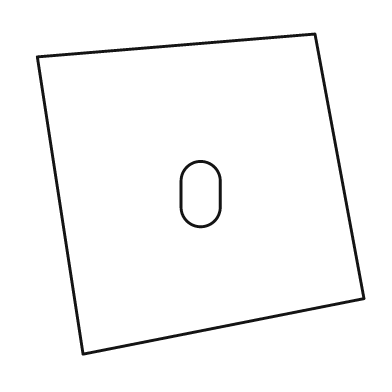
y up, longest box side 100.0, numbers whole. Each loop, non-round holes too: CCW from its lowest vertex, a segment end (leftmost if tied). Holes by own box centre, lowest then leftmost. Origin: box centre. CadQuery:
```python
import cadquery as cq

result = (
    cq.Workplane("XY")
    .moveTo(-36.0, -49.0)
    .lineTo(50.0, -32.0)
    .lineTo(35.0, 49.0)
    .lineTo(-50.0, 42.0)
    .close()
    .moveTo(-6.0, -4.0)
    .threePointArc((0.0, -10.0), (6.0, -4.0))
    .lineTo(6.0, 4.0)
    .threePointArc((0.0, 10.0), (-6.0, 4.0))
    .close()
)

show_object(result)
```